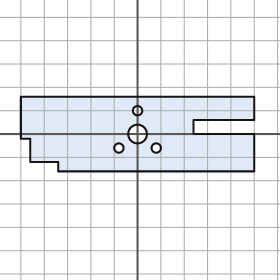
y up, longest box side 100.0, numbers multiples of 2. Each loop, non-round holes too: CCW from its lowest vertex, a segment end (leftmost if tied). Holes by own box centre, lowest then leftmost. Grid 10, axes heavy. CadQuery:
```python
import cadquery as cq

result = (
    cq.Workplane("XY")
    .moveTo(-34.0, -16.0)
    .lineTo(50.0, -16.0)
    .lineTo(50.0, 0.0)
    .lineTo(24.0, 0.0)
    .lineTo(24.0, 6.0)
    .lineTo(50.0, 6.0)
    .lineTo(50.0, 16.0)
    .lineTo(-50.0, 16.0)
    .lineTo(-50.0, -2.0)
    .lineTo(-46.0, -2.0)
    .lineTo(-46.0, -12.0)
    .lineTo(-34.0, -12.0)
    .close()
    .moveTo(-8.0, -6.0)
    .circle(2.0)
    .moveTo(8.0, -6.0)
    .circle(2.0)
    .moveTo(0.0, 0.0)
    .circle(4.0)
    .moveTo(0.0, 10.0)
    .circle(2.0)
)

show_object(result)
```